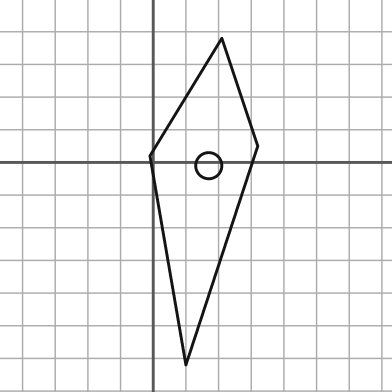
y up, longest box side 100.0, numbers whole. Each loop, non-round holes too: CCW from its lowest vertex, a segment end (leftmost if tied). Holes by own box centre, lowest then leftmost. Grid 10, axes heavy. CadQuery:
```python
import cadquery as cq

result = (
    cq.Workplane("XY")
    .moveTo(10.0, -62.0)
    .lineTo(32.0, 5.0)
    .lineTo(21.0, 38.0)
    .lineTo(-1.0, 2.0)
    .close()
    .moveTo(17.0, -1.0)
    .circle(4.0)
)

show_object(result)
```